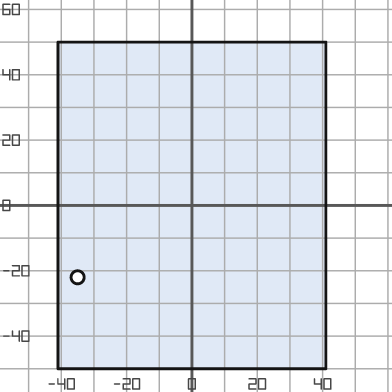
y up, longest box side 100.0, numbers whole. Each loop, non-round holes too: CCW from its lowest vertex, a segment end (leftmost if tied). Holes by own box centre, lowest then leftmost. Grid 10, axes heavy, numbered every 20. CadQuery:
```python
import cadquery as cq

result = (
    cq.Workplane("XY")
    .moveTo(-41.0, -50.0)
    .lineTo(41.0, -50.0)
    .lineTo(41.0, 50.0)
    .lineTo(-41.0, 50.0)
    .close()
    .moveTo(-35.0, -22.0)
    .circle(2.0)
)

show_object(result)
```